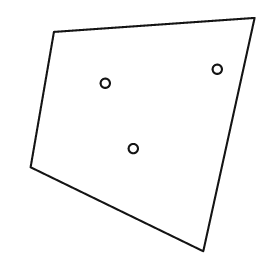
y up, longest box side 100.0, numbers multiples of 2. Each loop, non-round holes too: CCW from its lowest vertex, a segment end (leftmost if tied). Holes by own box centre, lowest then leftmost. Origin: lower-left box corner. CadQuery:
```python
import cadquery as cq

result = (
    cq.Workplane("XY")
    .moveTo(74.0, 0.0)
    .lineTo(96.0, 100.0)
    .lineTo(10.0, 94.0)
    .lineTo(0.0, 36.0)
    .close()
    .moveTo(44.0, 44.0)
    .circle(2.0)
    .moveTo(32.0, 72.0)
    .circle(2.0)
    .moveTo(80.0, 78.0)
    .circle(2.0)
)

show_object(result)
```